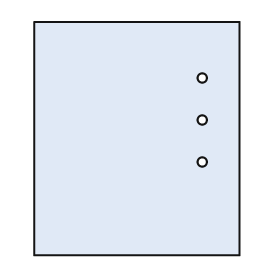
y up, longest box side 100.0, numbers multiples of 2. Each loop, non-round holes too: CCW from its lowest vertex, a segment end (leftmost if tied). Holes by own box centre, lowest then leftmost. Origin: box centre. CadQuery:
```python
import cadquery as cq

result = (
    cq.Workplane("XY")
    .moveTo(-44.0, -50.0)
    .lineTo(44.0, -50.0)
    .lineTo(44.0, 50.0)
    .lineTo(-44.0, 50.0)
    .close()
    .moveTo(28.0, -10.0)
    .circle(2.0)
    .moveTo(28.0, 8.0)
    .circle(2.0)
    .moveTo(28.0, 26.0)
    .circle(2.0)
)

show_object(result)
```